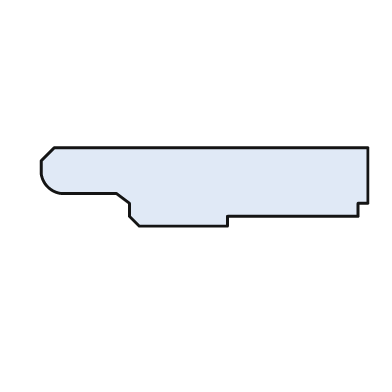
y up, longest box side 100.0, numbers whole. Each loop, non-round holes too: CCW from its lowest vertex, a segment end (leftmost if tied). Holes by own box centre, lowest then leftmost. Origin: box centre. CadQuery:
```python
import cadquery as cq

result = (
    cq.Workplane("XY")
    .moveTo(-20.0, -12.0)
    .lineTo(7.0, -12.0)
    .lineTo(7.0, -9.0)
    .lineTo(47.0, -9.0)
    .lineTo(47.0, -5.0)
    .lineTo(50.0, -5.0)
    .lineTo(50.0, 12.0)
    .lineTo(-46.0, 12.0)
    .lineTo(-50.0, 8.0)
    .lineTo(-50.0, 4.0)
    .threePointArc((-48.0, 0.0), (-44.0, -2.0))
    .lineTo(-27.0, -2.0)
    .lineTo(-23.0, -5.0)
    .lineTo(-23.0, -9.0)
    .close()
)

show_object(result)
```